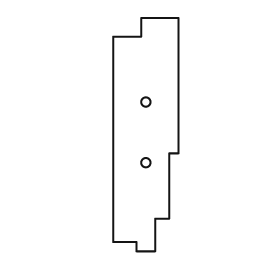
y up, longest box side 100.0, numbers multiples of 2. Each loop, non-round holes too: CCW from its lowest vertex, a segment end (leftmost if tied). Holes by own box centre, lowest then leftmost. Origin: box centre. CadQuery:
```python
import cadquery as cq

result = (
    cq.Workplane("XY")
    .moveTo(-4.0, -50.0)
    .lineTo(4.0, -50.0)
    .lineTo(4.0, -36.0)
    .lineTo(10.0, -36.0)
    .lineTo(10.0, -8.0)
    .lineTo(14.0, -8.0)
    .lineTo(14.0, 50.0)
    .lineTo(-2.0, 50.0)
    .lineTo(-2.0, 42.0)
    .lineTo(-14.0, 42.0)
    .lineTo(-14.0, -46.0)
    .lineTo(-4.0, -46.0)
    .close()
    .moveTo(0.0, -12.0)
    .circle(2.0)
    .moveTo(0.0, 14.0)
    .circle(2.0)
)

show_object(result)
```